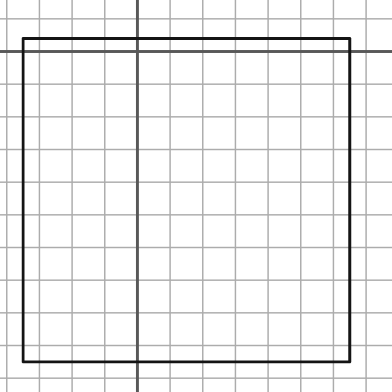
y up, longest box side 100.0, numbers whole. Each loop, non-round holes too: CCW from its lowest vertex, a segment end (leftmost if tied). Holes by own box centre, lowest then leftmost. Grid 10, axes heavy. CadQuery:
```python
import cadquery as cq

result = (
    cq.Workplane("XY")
    .moveTo(-35.0, -95.0)
    .lineTo(65.0, -95.0)
    .lineTo(65.0, 4.0)
    .lineTo(-35.0, 4.0)
    .close()
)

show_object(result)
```